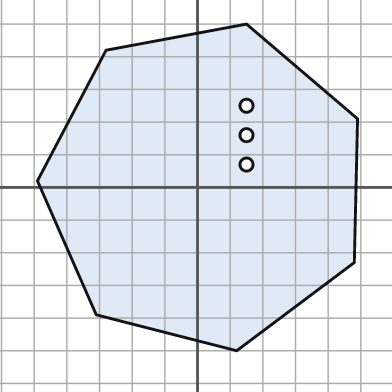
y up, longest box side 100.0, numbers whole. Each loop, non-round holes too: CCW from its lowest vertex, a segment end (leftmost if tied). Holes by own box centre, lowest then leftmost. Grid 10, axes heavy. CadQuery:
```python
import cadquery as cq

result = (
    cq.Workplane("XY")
    .moveTo(12.0, -50.0)
    .lineTo(48.0, -23.0)
    .lineTo(49.0, 21.0)
    .lineTo(15.0, 50.0)
    .lineTo(-28.0, 42.0)
    .lineTo(-49.0, 2.0)
    .lineTo(-31.0, -39.0)
    .close()
    .moveTo(15.0, 7.0)
    .circle(2.0)
    .moveTo(15.0, 16.0)
    .circle(2.0)
    .moveTo(15.0, 25.0)
    .circle(2.0)
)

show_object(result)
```